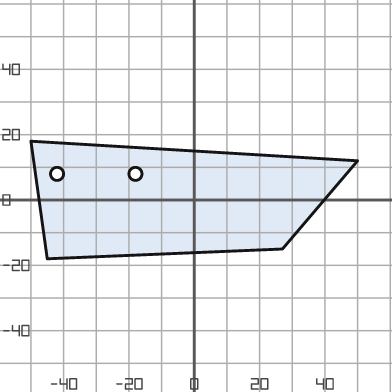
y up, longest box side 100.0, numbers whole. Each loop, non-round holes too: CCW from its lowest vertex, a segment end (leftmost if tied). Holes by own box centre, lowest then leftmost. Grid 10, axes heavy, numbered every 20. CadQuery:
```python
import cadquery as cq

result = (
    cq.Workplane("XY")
    .moveTo(-45.0, -18.0)
    .lineTo(27.0, -15.0)
    .lineTo(50.0, 12.0)
    .lineTo(-50.0, 18.0)
    .close()
    .moveTo(-42.0, 8.0)
    .circle(2.0)
    .moveTo(-18.0, 8.0)
    .circle(2.0)
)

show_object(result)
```